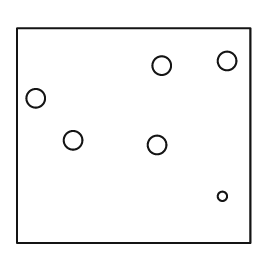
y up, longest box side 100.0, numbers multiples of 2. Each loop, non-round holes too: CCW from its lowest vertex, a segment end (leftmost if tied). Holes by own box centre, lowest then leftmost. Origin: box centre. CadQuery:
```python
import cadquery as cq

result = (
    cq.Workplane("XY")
    .moveTo(-50.0, -46.0)
    .lineTo(50.0, -46.0)
    .lineTo(50.0, 46.0)
    .lineTo(-50.0, 46.0)
    .close()
    .moveTo(38.0, -26.0)
    .circle(2.0)
    .moveTo(10.0, -4.0)
    .circle(4.0)
    .moveTo(-26.0, -2.0)
    .circle(4.0)
    .moveTo(-42.0, 16.0)
    .circle(4.0)
    .moveTo(12.0, 30.0)
    .circle(4.0)
    .moveTo(40.0, 32.0)
    .circle(4.0)
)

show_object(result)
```